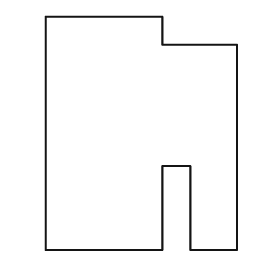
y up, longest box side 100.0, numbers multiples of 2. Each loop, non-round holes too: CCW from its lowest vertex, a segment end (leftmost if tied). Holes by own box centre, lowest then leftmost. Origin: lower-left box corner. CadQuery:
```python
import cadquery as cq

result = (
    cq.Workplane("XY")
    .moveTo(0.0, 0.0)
    .lineTo(50.0, 0.0)
    .lineTo(50.0, 36.0)
    .lineTo(62.0, 36.0)
    .lineTo(62.0, 0.0)
    .lineTo(82.0, 0.0)
    .lineTo(82.0, 88.0)
    .lineTo(50.0, 88.0)
    .lineTo(50.0, 100.0)
    .lineTo(0.0, 100.0)
    .close()
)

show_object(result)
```